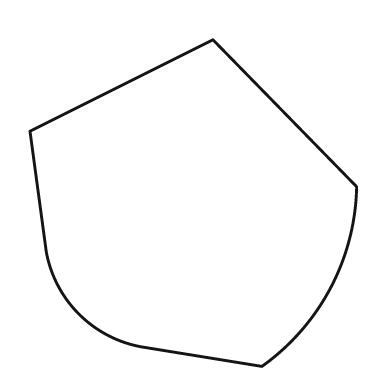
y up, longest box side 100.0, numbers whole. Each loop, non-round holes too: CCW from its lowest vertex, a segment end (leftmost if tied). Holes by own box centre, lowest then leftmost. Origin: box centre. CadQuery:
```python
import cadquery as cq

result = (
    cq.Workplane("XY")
    .moveTo(21.0, -50.0)
    .threePointArc((42.0, -26.0), (50.0, 5.0))
    .lineTo(6.0, 50.0)
    .lineTo(-50.0, 22.0)
    .lineTo(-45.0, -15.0)
    .threePointArc((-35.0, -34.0), (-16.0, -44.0))
    .close()
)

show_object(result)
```